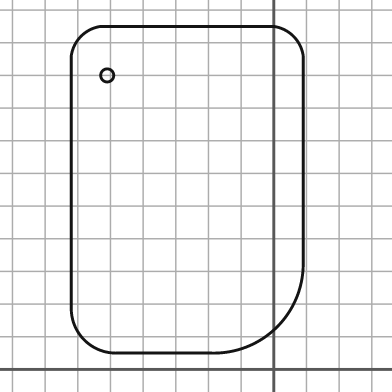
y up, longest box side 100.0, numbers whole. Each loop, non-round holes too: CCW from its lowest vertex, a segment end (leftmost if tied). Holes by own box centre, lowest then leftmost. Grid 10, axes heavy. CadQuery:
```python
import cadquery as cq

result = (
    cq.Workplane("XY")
    .moveTo(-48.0, 5.0)
    .lineTo(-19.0, 5.0)
    .threePointArc((1.0, 13.0), (9.0, 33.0))
    .lineTo(9.0, 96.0)
    .threePointArc((6.0, 102.0), (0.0, 105.0))
    .lineTo(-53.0, 105.0)
    .threePointArc((-59.0, 102.0), (-62.0, 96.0))
    .lineTo(-62.0, 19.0)
    .threePointArc((-58.0, 9.0), (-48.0, 5.0))
    .close()
    .moveTo(-51.0, 90.0)
    .circle(2.0)
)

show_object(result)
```